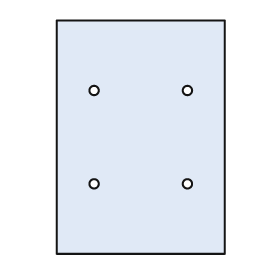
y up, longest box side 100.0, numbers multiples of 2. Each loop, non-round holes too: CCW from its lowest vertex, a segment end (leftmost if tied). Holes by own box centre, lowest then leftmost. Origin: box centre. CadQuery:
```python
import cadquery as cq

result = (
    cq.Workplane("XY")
    .moveTo(-36.0, -50.0)
    .lineTo(36.0, -50.0)
    .lineTo(36.0, 50.0)
    .lineTo(-36.0, 50.0)
    .close()
    .moveTo(-20.0, -20.0)
    .circle(2.0)
    .moveTo(20.0, -20.0)
    .circle(2.0)
    .moveTo(-20.0, 20.0)
    .circle(2.0)
    .moveTo(20.0, 20.0)
    .circle(2.0)
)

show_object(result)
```